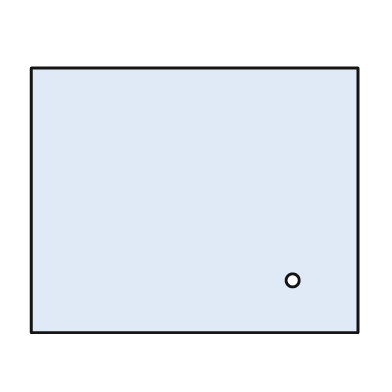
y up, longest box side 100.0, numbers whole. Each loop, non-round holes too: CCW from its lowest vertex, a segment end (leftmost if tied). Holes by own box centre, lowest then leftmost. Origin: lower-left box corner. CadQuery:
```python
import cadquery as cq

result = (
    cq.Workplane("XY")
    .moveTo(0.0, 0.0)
    .lineTo(100.0, 0.0)
    .lineTo(100.0, 81.0)
    .lineTo(0.0, 81.0)
    .close()
    .moveTo(80.0, 16.0)
    .circle(2.0)
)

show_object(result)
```